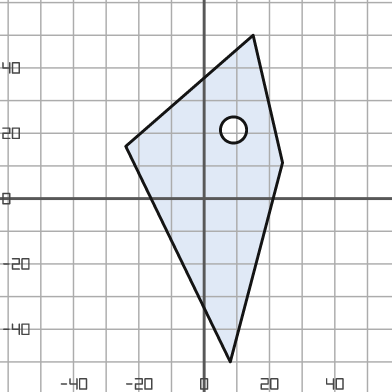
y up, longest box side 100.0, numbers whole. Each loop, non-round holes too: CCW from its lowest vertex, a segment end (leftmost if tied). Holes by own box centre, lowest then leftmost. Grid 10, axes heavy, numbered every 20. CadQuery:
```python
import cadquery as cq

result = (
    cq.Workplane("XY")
    .moveTo(8.0, -50.0)
    .lineTo(24.0, 11.0)
    .lineTo(15.0, 50.0)
    .lineTo(-24.0, 16.0)
    .close()
    .moveTo(9.0, 21.0)
    .circle(4.0)
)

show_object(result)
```